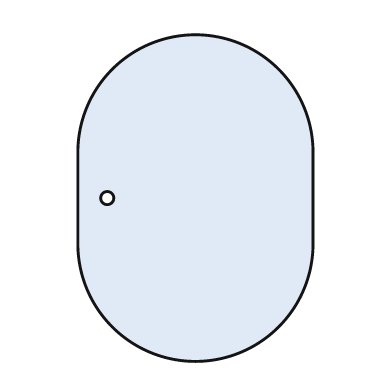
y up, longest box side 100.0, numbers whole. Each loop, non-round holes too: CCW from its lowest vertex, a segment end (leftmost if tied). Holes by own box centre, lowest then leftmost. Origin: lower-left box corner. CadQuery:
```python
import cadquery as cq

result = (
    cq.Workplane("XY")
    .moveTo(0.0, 36.0)
    .threePointArc((36.0, 0.0), (72.0, 36.0))
    .lineTo(72.0, 64.0)
    .threePointArc((36.0, 100.0), (0.0, 64.0))
    .close()
    .moveTo(9.0, 50.0)
    .circle(2.0)
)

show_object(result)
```